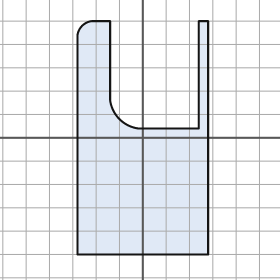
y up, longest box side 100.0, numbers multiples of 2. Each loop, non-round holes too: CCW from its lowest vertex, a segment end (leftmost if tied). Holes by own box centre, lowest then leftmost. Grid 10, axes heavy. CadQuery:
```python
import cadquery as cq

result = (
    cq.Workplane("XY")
    .moveTo(-28.0, -50.0)
    .lineTo(28.0, -50.0)
    .lineTo(28.0, 50.0)
    .lineTo(24.0, 50.0)
    .lineTo(24.0, 4.0)
    .lineTo(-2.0, 4.0)
    .threePointArc((-10.0, 8.0), (-14.0, 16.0))
    .lineTo(-14.0, 50.0)
    .lineTo(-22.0, 50.0)
    .threePointArc((-26.0, 48.0), (-28.0, 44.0))
    .close()
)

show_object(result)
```